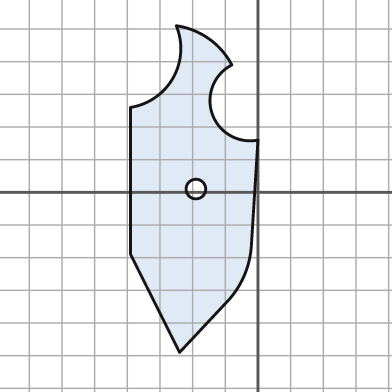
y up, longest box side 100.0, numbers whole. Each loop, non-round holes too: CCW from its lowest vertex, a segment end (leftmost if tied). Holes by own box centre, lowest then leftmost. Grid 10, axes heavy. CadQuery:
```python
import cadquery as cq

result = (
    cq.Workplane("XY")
    .moveTo(-24.0, -49.0)
    .lineTo(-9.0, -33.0)
    .threePointArc((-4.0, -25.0), (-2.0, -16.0))
    .lineTo(0.0, 16.0)
    .threePointArc((-14.0, 24.0), (-8.0, 39.0))
    .threePointArc((-15.0, 47.0), (-25.0, 51.0))
    .threePointArc((-26.0, 35.0), (-39.0, 26.0))
    .lineTo(-39.0, -19.0)
    .close()
    .moveTo(-19.0, 1.0)
    .circle(3.0)
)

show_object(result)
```